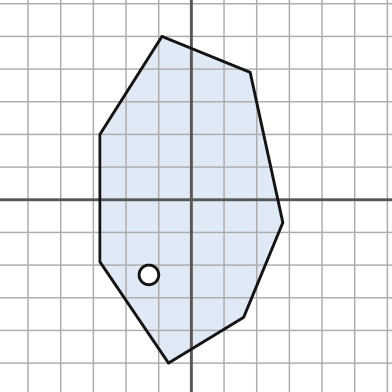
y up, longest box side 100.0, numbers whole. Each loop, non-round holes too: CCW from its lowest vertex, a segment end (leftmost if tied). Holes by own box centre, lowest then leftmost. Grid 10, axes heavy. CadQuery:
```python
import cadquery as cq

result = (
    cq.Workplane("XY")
    .moveTo(-7.0, -50.0)
    .lineTo(16.0, -36.0)
    .lineTo(28.0, -7.0)
    .lineTo(18.0, 39.0)
    .lineTo(-9.0, 50.0)
    .lineTo(-28.0, 20.0)
    .lineTo(-28.0, -19.0)
    .close()
    .moveTo(-13.0, -23.0)
    .circle(3.0)
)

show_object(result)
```